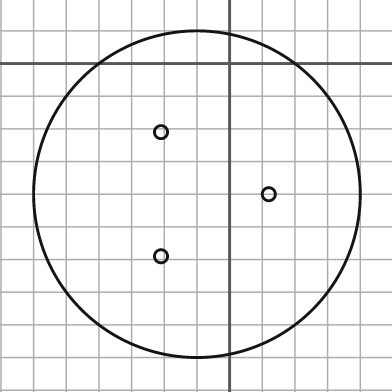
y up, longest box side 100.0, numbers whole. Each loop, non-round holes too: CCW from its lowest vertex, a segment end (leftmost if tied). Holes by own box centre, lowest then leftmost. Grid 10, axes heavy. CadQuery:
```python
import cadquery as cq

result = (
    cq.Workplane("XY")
    .moveTo(-10.0, -40.0)
    .circle(50.0)
    .moveTo(-21.0, -59.0)
    .circle(2.0)
    .moveTo(12.0, -40.0)
    .circle(2.0)
    .moveTo(-21.0, -21.0)
    .circle(2.0)
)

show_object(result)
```